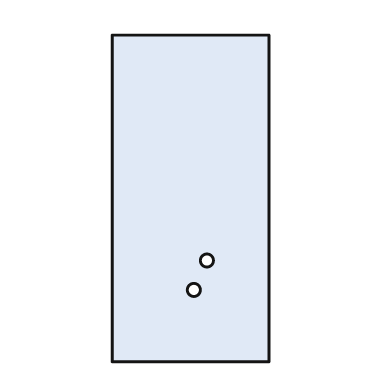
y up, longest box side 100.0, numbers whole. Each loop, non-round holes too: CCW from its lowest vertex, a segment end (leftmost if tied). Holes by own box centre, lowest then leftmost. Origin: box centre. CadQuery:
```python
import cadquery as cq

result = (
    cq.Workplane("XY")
    .moveTo(-24.0, -50.0)
    .lineTo(24.0, -50.0)
    .lineTo(24.0, 50.0)
    .lineTo(-24.0, 50.0)
    .close()
    .moveTo(1.0, -28.0)
    .circle(2.0)
    .moveTo(5.0, -19.0)
    .circle(2.0)
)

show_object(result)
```